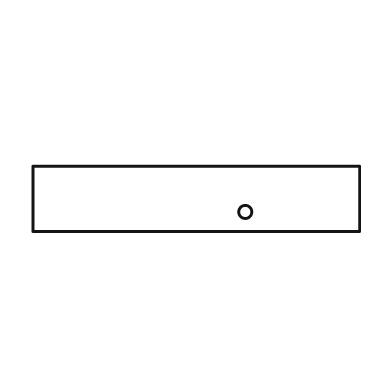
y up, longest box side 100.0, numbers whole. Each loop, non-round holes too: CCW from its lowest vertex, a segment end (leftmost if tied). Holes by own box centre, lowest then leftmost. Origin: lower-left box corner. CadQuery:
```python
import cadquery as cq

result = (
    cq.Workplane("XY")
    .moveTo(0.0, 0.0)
    .lineTo(100.0, 0.0)
    .lineTo(100.0, 20.0)
    .lineTo(0.0, 20.0)
    .close()
    .moveTo(65.0, 6.0)
    .circle(2.0)
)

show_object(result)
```